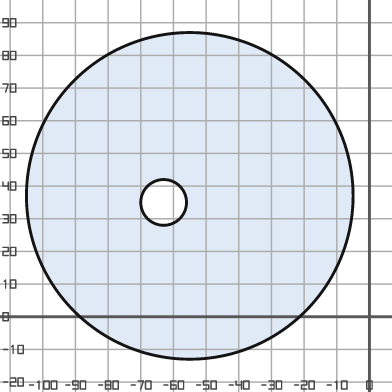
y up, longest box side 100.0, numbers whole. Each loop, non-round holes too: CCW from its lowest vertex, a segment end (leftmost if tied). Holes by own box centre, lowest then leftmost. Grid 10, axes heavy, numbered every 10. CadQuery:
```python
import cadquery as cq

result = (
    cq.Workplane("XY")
    .moveTo(-55.0, 37.0)
    .circle(50.0)
    .moveTo(-63.0, 35.0)
    .circle(7.0)
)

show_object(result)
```